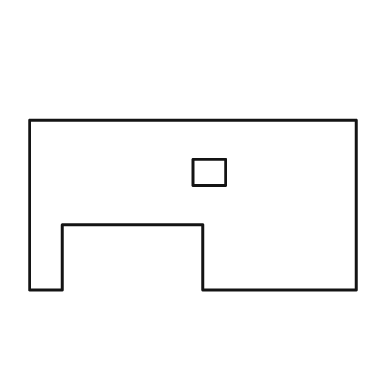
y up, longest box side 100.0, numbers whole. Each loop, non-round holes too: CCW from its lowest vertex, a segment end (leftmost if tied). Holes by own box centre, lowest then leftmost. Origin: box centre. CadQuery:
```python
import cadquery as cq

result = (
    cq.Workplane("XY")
    .moveTo(-50.0, -26.0)
    .lineTo(-40.0, -26.0)
    .lineTo(-40.0, -6.0)
    .lineTo(3.0, -6.0)
    .lineTo(3.0, -26.0)
    .lineTo(50.0, -26.0)
    .lineTo(50.0, 26.0)
    .lineTo(-50.0, 26.0)
    .close()
    .moveTo(0.0, 6.0)
    .lineTo(10.0, 6.0)
    .lineTo(10.0, 14.0)
    .lineTo(0.0, 14.0)
    .close()
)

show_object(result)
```